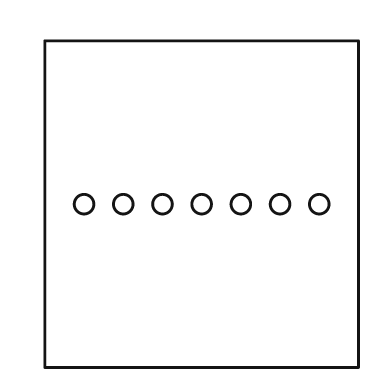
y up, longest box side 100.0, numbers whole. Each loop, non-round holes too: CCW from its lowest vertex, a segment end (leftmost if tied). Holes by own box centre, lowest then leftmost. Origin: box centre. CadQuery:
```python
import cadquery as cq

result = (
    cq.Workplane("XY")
    .moveTo(-48.0, -50.0)
    .lineTo(48.0, -50.0)
    .lineTo(48.0, 50.0)
    .lineTo(-48.0, 50.0)
    .close()
    .moveTo(-36.0, 0.0)
    .circle(3.0)
    .moveTo(-24.0, 0.0)
    .circle(3.0)
    .moveTo(-12.0, 0.0)
    .circle(3.0)
    .moveTo(0.0, 0.0)
    .circle(3.0)
    .moveTo(12.0, 0.0)
    .circle(3.0)
    .moveTo(24.0, 0.0)
    .circle(3.0)
    .moveTo(36.0, 0.0)
    .circle(3.0)
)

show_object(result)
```